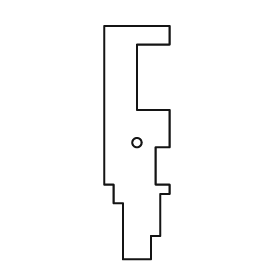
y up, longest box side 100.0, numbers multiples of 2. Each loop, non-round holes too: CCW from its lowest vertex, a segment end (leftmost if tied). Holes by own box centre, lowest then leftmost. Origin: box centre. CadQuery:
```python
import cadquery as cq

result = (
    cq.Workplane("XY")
    .moveTo(-6.0, -50.0)
    .lineTo(6.0, -50.0)
    .lineTo(6.0, -40.0)
    .lineTo(10.0, -40.0)
    .lineTo(10.0, -22.0)
    .lineTo(14.0, -22.0)
    .lineTo(14.0, -18.0)
    .lineTo(8.0, -18.0)
    .lineTo(8.0, -2.0)
    .lineTo(14.0, -2.0)
    .lineTo(14.0, 14.0)
    .lineTo(0.0, 14.0)
    .lineTo(0.0, 42.0)
    .lineTo(14.0, 42.0)
    .lineTo(14.0, 50.0)
    .lineTo(-14.0, 50.0)
    .lineTo(-14.0, -18.0)
    .lineTo(-10.0, -18.0)
    .lineTo(-10.0, -26.0)
    .lineTo(-6.0, -26.0)
    .close()
    .moveTo(0.0, 0.0)
    .circle(2.0)
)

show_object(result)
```